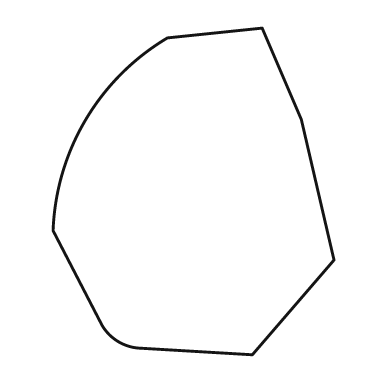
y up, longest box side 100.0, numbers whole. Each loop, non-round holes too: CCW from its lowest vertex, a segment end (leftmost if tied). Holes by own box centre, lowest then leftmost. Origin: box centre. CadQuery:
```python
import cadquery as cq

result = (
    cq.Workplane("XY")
    .moveTo(18.0, -50.0)
    .lineTo(43.0, -21.0)
    .lineTo(33.0, 22.0)
    .lineTo(21.0, 50.0)
    .lineTo(-8.0, 47.0)
    .threePointArc((-33.0, 22.0), (-43.0, -12.0))
    .lineTo(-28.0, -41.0)
    .threePointArc((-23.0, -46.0), (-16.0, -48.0))
    .close()
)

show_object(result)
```